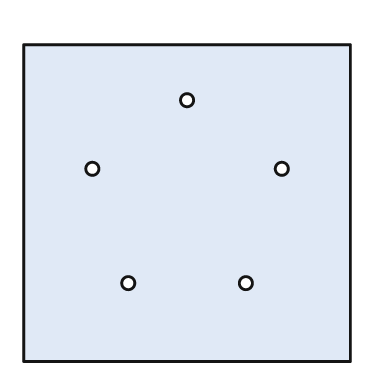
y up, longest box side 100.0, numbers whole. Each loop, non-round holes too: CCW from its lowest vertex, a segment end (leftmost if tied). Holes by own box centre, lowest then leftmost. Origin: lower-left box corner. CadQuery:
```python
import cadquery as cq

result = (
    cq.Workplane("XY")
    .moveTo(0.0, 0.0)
    .lineTo(100.0, 0.0)
    .lineTo(100.0, 97.0)
    .lineTo(0.0, 97.0)
    .close()
    .moveTo(32.0, 24.0)
    .circle(2.0)
    .moveTo(68.0, 24.0)
    .circle(2.0)
    .moveTo(21.0, 59.0)
    .circle(2.0)
    .moveTo(79.0, 59.0)
    .circle(2.0)
    .moveTo(50.0, 80.0)
    .circle(2.0)
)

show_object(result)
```